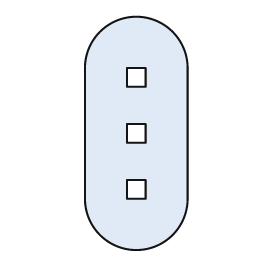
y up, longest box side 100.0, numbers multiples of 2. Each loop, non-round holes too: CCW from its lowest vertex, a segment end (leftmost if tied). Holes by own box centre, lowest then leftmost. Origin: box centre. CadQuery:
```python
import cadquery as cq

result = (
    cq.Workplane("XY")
    .moveTo(-22.0, -28.0)
    .threePointArc((0.0, -50.0), (22.0, -28.0))
    .lineTo(22.0, 28.0)
    .threePointArc((0.0, 50.0), (-22.0, 28.0))
    .close()
    .moveTo(-4.0, -28.0)
    .lineTo(4.0, -28.0)
    .lineTo(4.0, -20.0)
    .lineTo(-4.0, -20.0)
    .close()
    .moveTo(-4.0, -4.0)
    .lineTo(4.0, -4.0)
    .lineTo(4.0, 4.0)
    .lineTo(-4.0, 4.0)
    .close()
    .moveTo(-4.0, 20.0)
    .lineTo(4.0, 20.0)
    .lineTo(4.0, 28.0)
    .lineTo(-4.0, 28.0)
    .close()
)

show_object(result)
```